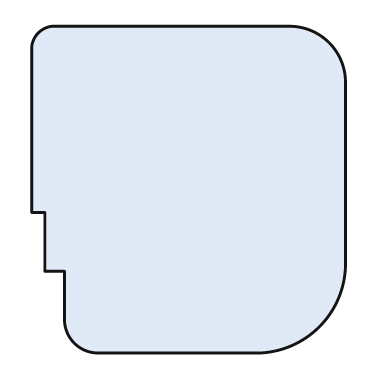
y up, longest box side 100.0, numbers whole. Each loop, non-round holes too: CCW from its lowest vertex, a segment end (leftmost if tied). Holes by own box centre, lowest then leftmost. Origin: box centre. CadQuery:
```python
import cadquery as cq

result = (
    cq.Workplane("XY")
    .moveTo(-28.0, -50.0)
    .lineTo(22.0, -50.0)
    .threePointArc((40.0, -42.0), (48.0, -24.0))
    .lineTo(48.0, 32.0)
    .threePointArc((43.0, 45.0), (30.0, 50.0))
    .lineTo(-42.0, 50.0)
    .threePointArc((-46.0, 48.0), (-48.0, 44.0))
    .lineTo(-48.0, -7.0)
    .lineTo(-44.0, -7.0)
    .lineTo(-44.0, -25.0)
    .lineTo(-38.0, -25.0)
    .lineTo(-38.0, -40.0)
    .threePointArc((-35.0, -47.0), (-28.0, -50.0))
    .close()
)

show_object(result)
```